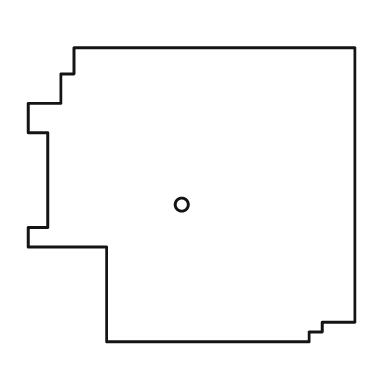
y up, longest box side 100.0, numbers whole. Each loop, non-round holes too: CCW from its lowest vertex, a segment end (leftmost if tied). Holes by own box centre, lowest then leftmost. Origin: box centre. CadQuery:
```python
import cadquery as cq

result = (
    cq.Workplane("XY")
    .moveTo(-26.0, -45.0)
    .lineTo(36.0, -45.0)
    .lineTo(36.0, -42.0)
    .lineTo(40.0, -42.0)
    .lineTo(40.0, -39.0)
    .lineTo(50.0, -39.0)
    .lineTo(50.0, 45.0)
    .lineTo(-36.0, 45.0)
    .lineTo(-36.0, 37.0)
    .lineTo(-40.0, 37.0)
    .lineTo(-40.0, 28.0)
    .lineTo(-50.0, 28.0)
    .lineTo(-50.0, 19.0)
    .lineTo(-44.0, 19.0)
    .lineTo(-44.0, -10.0)
    .lineTo(-50.0, -10.0)
    .lineTo(-50.0, -16.0)
    .lineTo(-26.0, -16.0)
    .close()
    .moveTo(-3.0, -3.0)
    .circle(2.0)
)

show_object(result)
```